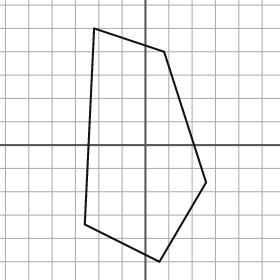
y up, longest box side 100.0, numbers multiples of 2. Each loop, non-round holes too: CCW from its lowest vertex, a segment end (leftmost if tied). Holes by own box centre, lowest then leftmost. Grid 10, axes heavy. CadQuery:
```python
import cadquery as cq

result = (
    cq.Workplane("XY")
    .moveTo(6.0, -50.0)
    .lineTo(26.0, -16.0)
    .lineTo(8.0, 40.0)
    .lineTo(-22.0, 50.0)
    .lineTo(-26.0, -34.0)
    .close()
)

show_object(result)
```